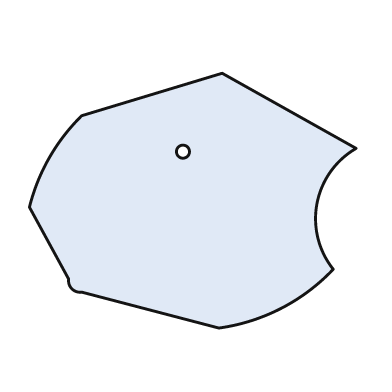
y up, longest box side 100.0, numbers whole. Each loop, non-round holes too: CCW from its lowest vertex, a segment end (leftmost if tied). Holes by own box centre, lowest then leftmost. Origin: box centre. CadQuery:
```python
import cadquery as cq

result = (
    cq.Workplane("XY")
    .moveTo(8.0, -39.0)
    .threePointArc((27.0, -33.0), (43.0, -21.0))
    .threePointArc((38.0, -1.0), (50.0, 16.0))
    .lineTo(9.0, 39.0)
    .lineTo(-34.0, 26.0)
    .threePointArc((-44.0, 13.0), (-50.0, -2.0))
    .lineTo(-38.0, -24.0)
    .threePointArc((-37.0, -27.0), (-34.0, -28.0))
    .close()
    .moveTo(-3.0, 15.0)
    .circle(2.0)
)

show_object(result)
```